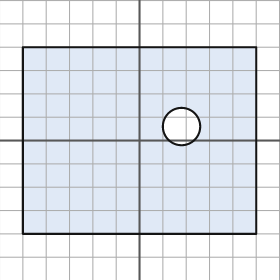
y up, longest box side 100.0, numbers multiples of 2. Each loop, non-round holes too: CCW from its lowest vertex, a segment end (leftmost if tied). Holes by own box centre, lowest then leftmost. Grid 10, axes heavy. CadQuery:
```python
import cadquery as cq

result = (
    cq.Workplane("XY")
    .moveTo(-50.0, -40.0)
    .lineTo(50.0, -40.0)
    .lineTo(50.0, 40.0)
    .lineTo(-50.0, 40.0)
    .close()
    .moveTo(18.0, 6.0)
    .circle(8.0)
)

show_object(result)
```